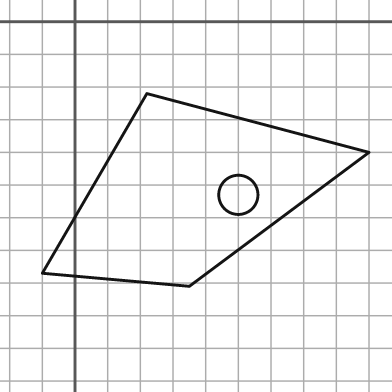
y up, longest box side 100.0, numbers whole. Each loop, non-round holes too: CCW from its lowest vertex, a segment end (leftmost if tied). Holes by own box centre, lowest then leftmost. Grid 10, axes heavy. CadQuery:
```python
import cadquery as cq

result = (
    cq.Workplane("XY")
    .moveTo(35.0, -81.0)
    .lineTo(90.0, -40.0)
    .lineTo(22.0, -22.0)
    .lineTo(-10.0, -77.0)
    .close()
    .moveTo(50.0, -53.0)
    .circle(6.0)
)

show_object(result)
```